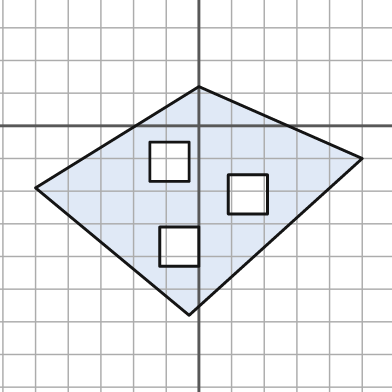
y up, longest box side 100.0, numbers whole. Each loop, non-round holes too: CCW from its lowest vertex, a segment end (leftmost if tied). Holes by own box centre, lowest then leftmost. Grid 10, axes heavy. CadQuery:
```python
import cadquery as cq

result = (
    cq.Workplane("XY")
    .moveTo(-3.0, -58.0)
    .lineTo(50.0, -10.0)
    .lineTo(0.0, 12.0)
    .lineTo(-50.0, -19.0)
    .close()
    .moveTo(-12.0, -43.0)
    .lineTo(0.0, -43.0)
    .lineTo(0.0, -31.0)
    .lineTo(-12.0, -31.0)
    .close()
    .moveTo(9.0, -27.0)
    .lineTo(21.0, -27.0)
    .lineTo(21.0, -15.0)
    .lineTo(9.0, -15.0)
    .close()
    .moveTo(-15.0, -17.0)
    .lineTo(-3.0, -17.0)
    .lineTo(-3.0, -5.0)
    .lineTo(-15.0, -5.0)
    .close()
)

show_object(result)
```